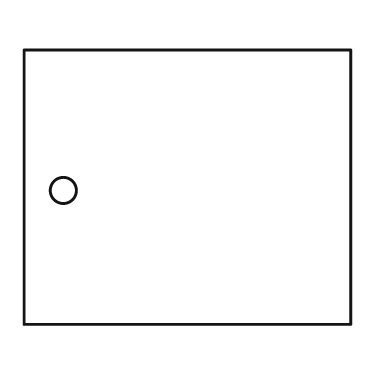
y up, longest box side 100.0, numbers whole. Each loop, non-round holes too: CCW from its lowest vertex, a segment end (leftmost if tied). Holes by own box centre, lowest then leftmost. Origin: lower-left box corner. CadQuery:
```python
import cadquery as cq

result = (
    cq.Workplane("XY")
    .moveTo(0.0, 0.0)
    .lineTo(100.0, 0.0)
    .lineTo(100.0, 84.0)
    .lineTo(0.0, 84.0)
    .close()
    .moveTo(12.0, 41.0)
    .circle(4.0)
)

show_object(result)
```